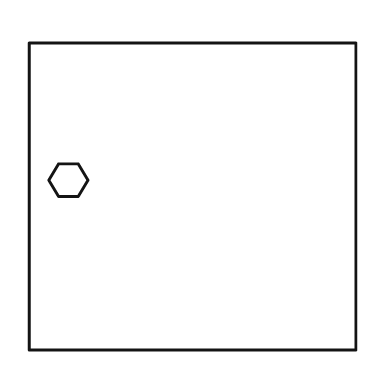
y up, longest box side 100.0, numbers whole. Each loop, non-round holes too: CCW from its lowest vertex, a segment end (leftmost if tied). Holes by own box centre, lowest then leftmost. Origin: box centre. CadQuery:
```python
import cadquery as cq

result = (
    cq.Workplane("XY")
    .moveTo(-50.0, -47.0)
    .lineTo(50.0, -47.0)
    .lineTo(50.0, 47.0)
    .lineTo(-50.0, 47.0)
    .close()
    .moveTo(-41.0, 0.0)
    .lineTo(-35.0, 0.0)
    .lineTo(-32.0, 5.0)
    .lineTo(-35.0, 10.0)
    .lineTo(-41.0, 10.0)
    .lineTo(-44.0, 5.0)
    .close()
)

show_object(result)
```